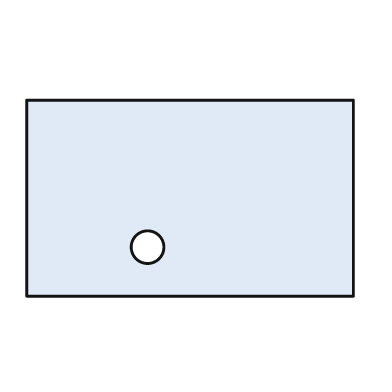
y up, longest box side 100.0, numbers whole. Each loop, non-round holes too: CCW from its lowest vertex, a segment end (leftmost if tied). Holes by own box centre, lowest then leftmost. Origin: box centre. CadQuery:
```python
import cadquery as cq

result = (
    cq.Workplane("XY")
    .moveTo(-50.0, -30.0)
    .lineTo(50.0, -30.0)
    .lineTo(50.0, 30.0)
    .lineTo(-50.0, 30.0)
    .close()
    .moveTo(-13.0, -15.0)
    .circle(5.0)
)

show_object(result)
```